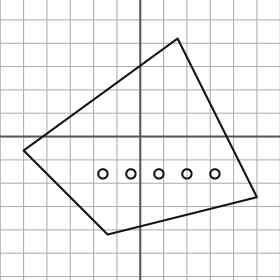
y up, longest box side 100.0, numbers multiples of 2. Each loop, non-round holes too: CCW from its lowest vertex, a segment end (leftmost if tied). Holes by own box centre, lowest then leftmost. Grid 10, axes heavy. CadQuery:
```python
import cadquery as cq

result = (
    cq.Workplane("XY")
    .moveTo(-14.0, -42.0)
    .lineTo(50.0, -26.0)
    .lineTo(16.0, 42.0)
    .lineTo(-50.0, -6.0)
    .close()
    .moveTo(-16.0, -16.0)
    .circle(2.0)
    .moveTo(-4.0, -16.0)
    .circle(2.0)
    .moveTo(8.0, -16.0)
    .circle(2.0)
    .moveTo(20.0, -16.0)
    .circle(2.0)
    .moveTo(32.0, -16.0)
    .circle(2.0)
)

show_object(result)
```